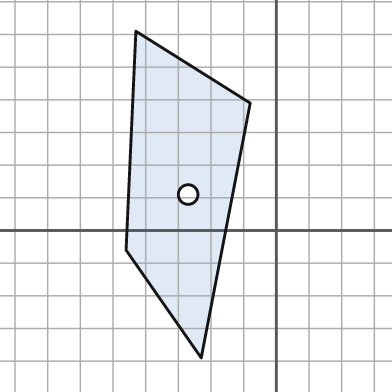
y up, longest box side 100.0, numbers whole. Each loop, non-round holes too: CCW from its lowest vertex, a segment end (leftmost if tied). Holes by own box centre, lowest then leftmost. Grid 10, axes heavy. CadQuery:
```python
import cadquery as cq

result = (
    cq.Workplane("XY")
    .moveTo(-23.0, -39.0)
    .lineTo(-8.0, 39.0)
    .lineTo(-43.0, 61.0)
    .lineTo(-46.0, -6.0)
    .close()
    .moveTo(-27.0, 11.0)
    .circle(3.0)
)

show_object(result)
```